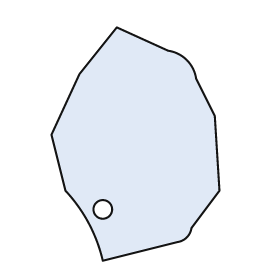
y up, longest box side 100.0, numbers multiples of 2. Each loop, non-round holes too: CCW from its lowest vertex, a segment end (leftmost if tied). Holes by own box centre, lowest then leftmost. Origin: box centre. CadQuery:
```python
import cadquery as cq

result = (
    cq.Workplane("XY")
    .moveTo(-14.0, -50.0)
    .lineTo(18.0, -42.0)
    .threePointArc((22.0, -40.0), (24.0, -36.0))
    .lineTo(36.0, -20.0)
    .lineTo(34.0, 12.0)
    .lineTo(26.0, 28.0)
    .threePointArc((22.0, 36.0), (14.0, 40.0))
    .lineTo(-8.0, 50.0)
    .lineTo(-24.0, 30.0)
    .lineTo(-36.0, 4.0)
    .lineTo(-30.0, -20.0)
    .threePointArc((-20.0, -34.0), (-14.0, -50.0))
    .close()
    .moveTo(-14.0, -28.0)
    .circle(4.0)
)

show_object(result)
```